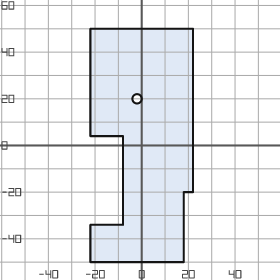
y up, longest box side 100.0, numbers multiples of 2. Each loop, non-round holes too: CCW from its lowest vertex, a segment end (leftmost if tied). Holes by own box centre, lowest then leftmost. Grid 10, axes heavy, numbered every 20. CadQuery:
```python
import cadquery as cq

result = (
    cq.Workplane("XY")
    .moveTo(-22.0, -50.0)
    .lineTo(18.0, -50.0)
    .lineTo(18.0, -20.0)
    .lineTo(22.0, -20.0)
    .lineTo(22.0, 50.0)
    .lineTo(-22.0, 50.0)
    .lineTo(-22.0, 4.0)
    .lineTo(-8.0, 4.0)
    .lineTo(-8.0, -34.0)
    .lineTo(-22.0, -34.0)
    .close()
    .moveTo(-2.0, 20.0)
    .circle(2.0)
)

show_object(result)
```